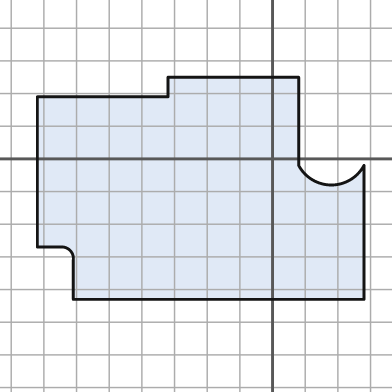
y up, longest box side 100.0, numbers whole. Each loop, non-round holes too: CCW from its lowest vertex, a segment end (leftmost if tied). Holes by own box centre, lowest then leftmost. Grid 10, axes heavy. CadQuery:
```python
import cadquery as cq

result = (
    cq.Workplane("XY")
    .moveTo(-61.0, -43.0)
    .lineTo(28.0, -43.0)
    .lineTo(28.0, -2.0)
    .threePointArc((18.0, -8.0), (8.0, -2.0))
    .lineTo(8.0, 25.0)
    .lineTo(-32.0, 25.0)
    .lineTo(-32.0, 19.0)
    .lineTo(-72.0, 19.0)
    .lineTo(-72.0, -27.0)
    .lineTo(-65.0, -27.0)
    .threePointArc((-62.0, -28.0), (-61.0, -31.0))
    .close()
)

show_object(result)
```